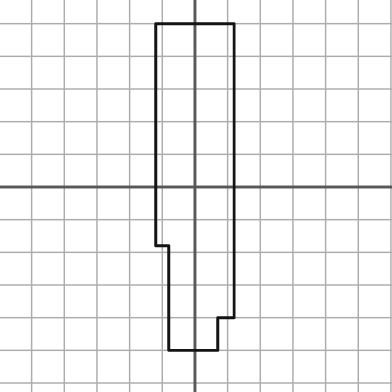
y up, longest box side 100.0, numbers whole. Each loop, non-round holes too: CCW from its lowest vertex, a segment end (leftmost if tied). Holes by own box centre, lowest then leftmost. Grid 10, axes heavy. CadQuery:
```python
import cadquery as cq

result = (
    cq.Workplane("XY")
    .moveTo(-8.0, -50.0)
    .lineTo(7.0, -50.0)
    .lineTo(7.0, -40.0)
    .lineTo(12.0, -40.0)
    .lineTo(12.0, 50.0)
    .lineTo(-12.0, 50.0)
    .lineTo(-12.0, -18.0)
    .lineTo(-8.0, -18.0)
    .close()
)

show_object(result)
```